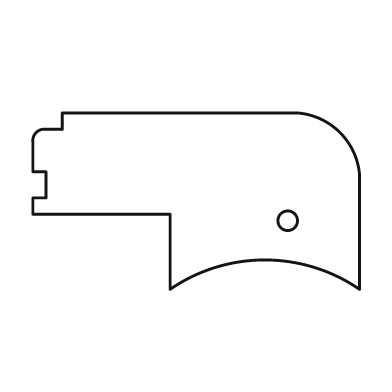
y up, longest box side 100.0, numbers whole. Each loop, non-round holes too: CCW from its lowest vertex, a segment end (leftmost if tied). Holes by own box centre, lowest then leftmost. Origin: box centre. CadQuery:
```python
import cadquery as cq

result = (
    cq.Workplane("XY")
    .moveTo(-8.0, -27.0)
    .threePointArc((21.0, -18.0), (50.0, -27.0))
    .lineTo(50.0, 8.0)
    .threePointArc((44.0, 21.0), (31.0, 27.0))
    .lineTo(-41.0, 27.0)
    .lineTo(-41.0, 22.0)
    .lineTo(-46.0, 22.0)
    .threePointArc((-49.0, 21.0), (-50.0, 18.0))
    .lineTo(-50.0, 9.0)
    .lineTo(-46.0, 9.0)
    .lineTo(-46.0, 1.0)
    .lineTo(-50.0, 1.0)
    .lineTo(-50.0, -4.0)
    .lineTo(-8.0, -4.0)
    .close()
    .moveTo(28.0, -6.0)
    .circle(3.0)
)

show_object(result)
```